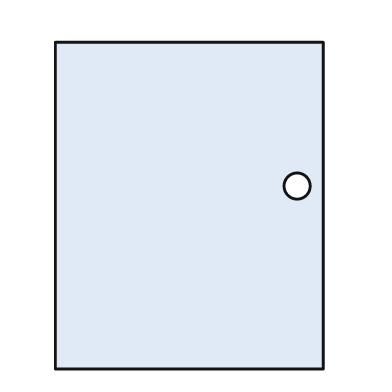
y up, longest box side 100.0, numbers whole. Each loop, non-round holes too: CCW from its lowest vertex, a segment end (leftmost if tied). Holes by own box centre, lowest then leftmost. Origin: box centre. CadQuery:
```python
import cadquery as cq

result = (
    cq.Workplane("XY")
    .moveTo(-41.0, -50.0)
    .lineTo(41.0, -50.0)
    .lineTo(41.0, 50.0)
    .lineTo(-41.0, 50.0)
    .close()
    .moveTo(33.0, 6.0)
    .circle(4.0)
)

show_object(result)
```